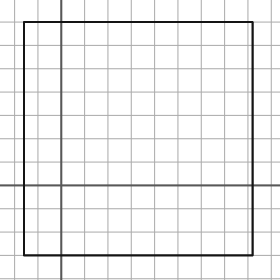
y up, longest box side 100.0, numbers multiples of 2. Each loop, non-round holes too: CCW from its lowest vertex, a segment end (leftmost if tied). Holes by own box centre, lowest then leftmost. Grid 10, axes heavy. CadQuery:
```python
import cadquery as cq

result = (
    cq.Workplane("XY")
    .moveTo(-16.0, -30.0)
    .lineTo(82.0, -30.0)
    .lineTo(82.0, 70.0)
    .lineTo(-16.0, 70.0)
    .close()
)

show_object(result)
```